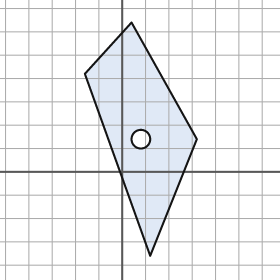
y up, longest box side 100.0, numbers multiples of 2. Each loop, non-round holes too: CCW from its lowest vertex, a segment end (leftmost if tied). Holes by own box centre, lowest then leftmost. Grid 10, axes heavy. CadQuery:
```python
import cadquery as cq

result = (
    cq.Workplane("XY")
    .moveTo(12.0, -36.0)
    .lineTo(32.0, 14.0)
    .lineTo(4.0, 64.0)
    .lineTo(-16.0, 42.0)
    .close()
    .moveTo(8.0, 14.0)
    .circle(4.0)
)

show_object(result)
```